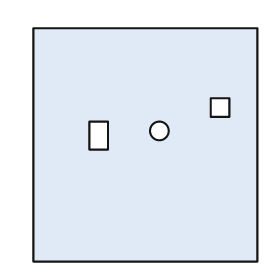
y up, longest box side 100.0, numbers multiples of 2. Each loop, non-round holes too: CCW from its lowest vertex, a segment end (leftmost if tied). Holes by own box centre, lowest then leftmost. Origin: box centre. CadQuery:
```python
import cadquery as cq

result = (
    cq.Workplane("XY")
    .moveTo(-48.0, -50.0)
    .lineTo(48.0, -50.0)
    .lineTo(48.0, 50.0)
    .lineTo(-48.0, 50.0)
    .close()
    .moveTo(-24.0, -2.0)
    .lineTo(-16.0, -2.0)
    .lineTo(-16.0, 10.0)
    .lineTo(-24.0, 10.0)
    .close()
    .moveTo(6.0, 6.0)
    .circle(4.0)
    .moveTo(28.0, 12.0)
    .lineTo(36.0, 12.0)
    .lineTo(36.0, 20.0)
    .lineTo(28.0, 20.0)
    .close()
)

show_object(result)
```